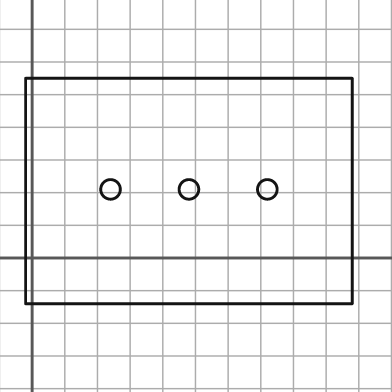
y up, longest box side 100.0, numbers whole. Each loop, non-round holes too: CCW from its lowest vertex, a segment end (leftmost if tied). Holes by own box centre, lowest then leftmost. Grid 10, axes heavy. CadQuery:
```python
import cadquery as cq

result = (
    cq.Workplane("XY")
    .moveTo(-2.0, -14.0)
    .lineTo(98.0, -14.0)
    .lineTo(98.0, 55.0)
    .lineTo(-2.0, 55.0)
    .close()
    .moveTo(24.0, 21.0)
    .circle(3.0)
    .moveTo(48.0, 21.0)
    .circle(3.0)
    .moveTo(72.0, 21.0)
    .circle(3.0)
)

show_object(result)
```